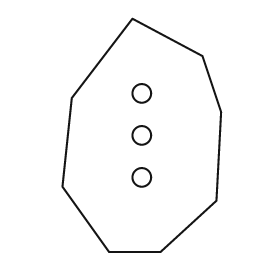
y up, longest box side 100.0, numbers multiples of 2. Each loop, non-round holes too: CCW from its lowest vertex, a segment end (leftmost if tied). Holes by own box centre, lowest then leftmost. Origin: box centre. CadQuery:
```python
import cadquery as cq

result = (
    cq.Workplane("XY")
    .moveTo(-14.0, -50.0)
    .lineTo(8.0, -50.0)
    .lineTo(32.0, -28.0)
    .lineTo(34.0, 10.0)
    .lineTo(26.0, 34.0)
    .lineTo(-4.0, 50.0)
    .lineTo(-30.0, 16.0)
    .lineTo(-34.0, -22.0)
    .close()
    .moveTo(0.0, -18.0)
    .circle(4.0)
    .moveTo(0.0, 0.0)
    .circle(4.0)
    .moveTo(0.0, 18.0)
    .circle(4.0)
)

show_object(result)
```